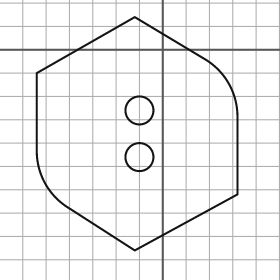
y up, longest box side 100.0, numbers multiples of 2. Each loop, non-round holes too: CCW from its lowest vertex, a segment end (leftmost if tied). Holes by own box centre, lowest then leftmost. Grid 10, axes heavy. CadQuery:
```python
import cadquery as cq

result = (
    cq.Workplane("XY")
    .moveTo(-12.0, -86.0)
    .lineTo(32.0, -62.0)
    .lineTo(32.0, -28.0)
    .threePointArc((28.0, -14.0), (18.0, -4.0))
    .lineTo(-12.0, 14.0)
    .lineTo(-54.0, -10.0)
    .lineTo(-54.0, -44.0)
    .threePointArc((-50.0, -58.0), (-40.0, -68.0))
    .close()
    .moveTo(-10.0, -46.0)
    .circle(6.0)
    .moveTo(-10.0, -26.0)
    .circle(6.0)
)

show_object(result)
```